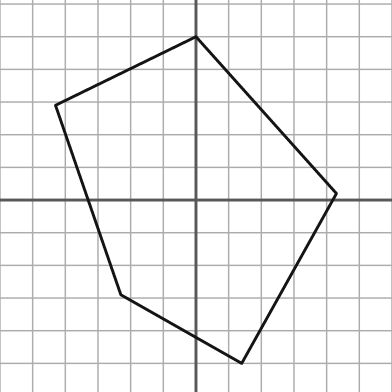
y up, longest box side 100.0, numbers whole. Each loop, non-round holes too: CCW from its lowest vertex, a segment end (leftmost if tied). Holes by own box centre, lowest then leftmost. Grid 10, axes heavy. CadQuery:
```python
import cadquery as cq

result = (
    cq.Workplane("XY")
    .moveTo(14.0, -50.0)
    .lineTo(43.0, 2.0)
    .lineTo(0.0, 50.0)
    .lineTo(-43.0, 29.0)
    .lineTo(-23.0, -29.0)
    .close()
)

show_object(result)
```